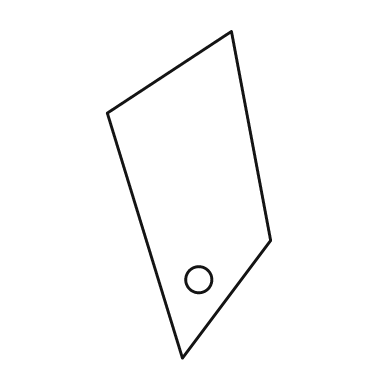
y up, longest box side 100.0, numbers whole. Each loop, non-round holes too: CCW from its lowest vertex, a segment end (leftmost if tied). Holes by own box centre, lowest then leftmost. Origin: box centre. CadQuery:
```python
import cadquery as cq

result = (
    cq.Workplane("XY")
    .moveTo(-2.0, -50.0)
    .lineTo(25.0, -14.0)
    .lineTo(13.0, 50.0)
    .lineTo(-25.0, 25.0)
    .close()
    .moveTo(3.0, -26.0)
    .circle(4.0)
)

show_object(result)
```